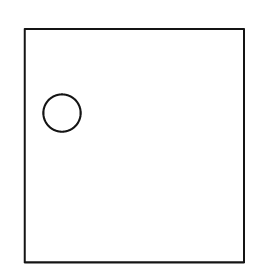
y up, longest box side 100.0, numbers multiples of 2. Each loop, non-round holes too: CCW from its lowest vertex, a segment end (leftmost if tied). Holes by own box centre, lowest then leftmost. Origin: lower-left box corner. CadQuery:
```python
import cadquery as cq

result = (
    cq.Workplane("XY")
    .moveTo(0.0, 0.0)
    .lineTo(94.0, 0.0)
    .lineTo(94.0, 100.0)
    .lineTo(0.0, 100.0)
    .close()
    .moveTo(16.0, 64.0)
    .circle(8.0)
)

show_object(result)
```